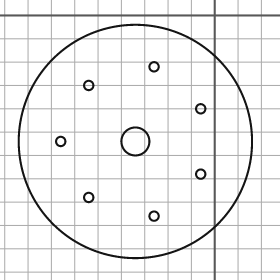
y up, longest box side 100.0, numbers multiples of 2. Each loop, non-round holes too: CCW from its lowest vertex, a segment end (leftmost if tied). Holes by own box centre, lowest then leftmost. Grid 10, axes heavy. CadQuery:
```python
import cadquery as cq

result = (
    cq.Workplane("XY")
    .moveTo(-34.0, -54.0)
    .circle(50.0)
    .moveTo(-26.0, -86.0)
    .circle(2.0)
    .moveTo(-54.0, -78.0)
    .circle(2.0)
    .moveTo(-6.0, -68.0)
    .circle(2.0)
    .moveTo(-66.0, -54.0)
    .circle(2.0)
    .moveTo(-34.0, -54.0)
    .circle(6.0)
    .moveTo(-6.0, -40.0)
    .circle(2.0)
    .moveTo(-54.0, -30.0)
    .circle(2.0)
    .moveTo(-26.0, -22.0)
    .circle(2.0)
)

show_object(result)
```